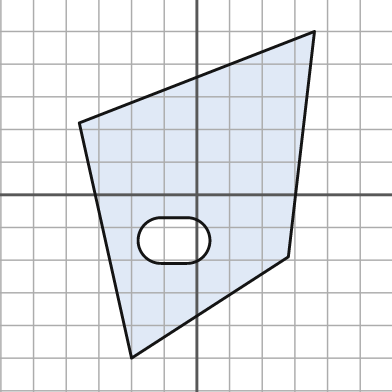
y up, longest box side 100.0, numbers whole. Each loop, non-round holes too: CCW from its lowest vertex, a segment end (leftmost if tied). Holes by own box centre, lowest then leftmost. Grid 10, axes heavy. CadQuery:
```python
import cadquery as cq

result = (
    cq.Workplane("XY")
    .moveTo(-20.0, -50.0)
    .lineTo(28.0, -19.0)
    .lineTo(36.0, 50.0)
    .lineTo(-36.0, 22.0)
    .close()
    .moveTo(-11.0, -21.0)
    .lineTo(-3.0, -21.0)
    .threePointArc((4.0, -14.0), (-3.0, -7.0))
    .lineTo(-11.0, -7.0)
    .threePointArc((-18.0, -14.0), (-11.0, -21.0))
    .close()
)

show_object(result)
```